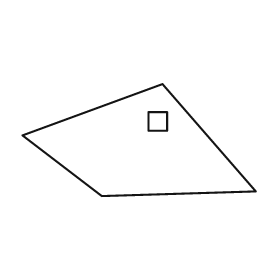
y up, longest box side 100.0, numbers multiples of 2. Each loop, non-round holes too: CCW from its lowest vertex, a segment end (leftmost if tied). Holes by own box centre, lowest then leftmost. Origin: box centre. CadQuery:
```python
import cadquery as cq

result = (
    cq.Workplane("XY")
    .moveTo(-16.0, -24.0)
    .lineTo(50.0, -22.0)
    .lineTo(10.0, 24.0)
    .lineTo(-50.0, 2.0)
    .close()
    .moveTo(4.0, 4.0)
    .lineTo(12.0, 4.0)
    .lineTo(12.0, 12.0)
    .lineTo(4.0, 12.0)
    .close()
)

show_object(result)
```